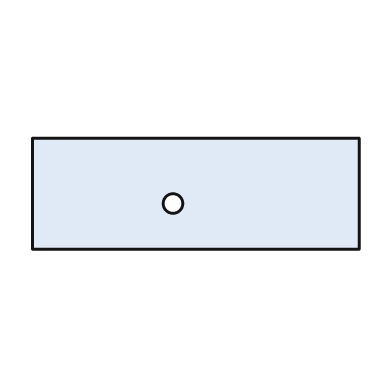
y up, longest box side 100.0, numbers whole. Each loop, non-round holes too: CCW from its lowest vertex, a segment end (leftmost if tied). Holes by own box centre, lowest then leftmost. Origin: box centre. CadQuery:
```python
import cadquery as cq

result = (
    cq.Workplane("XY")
    .moveTo(-50.0, -17.0)
    .lineTo(50.0, -17.0)
    .lineTo(50.0, 17.0)
    .lineTo(-50.0, 17.0)
    .close()
    .moveTo(-7.0, -3.0)
    .circle(3.0)
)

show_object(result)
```